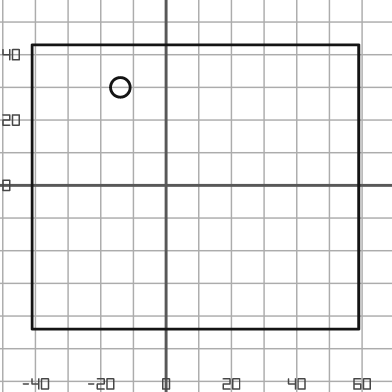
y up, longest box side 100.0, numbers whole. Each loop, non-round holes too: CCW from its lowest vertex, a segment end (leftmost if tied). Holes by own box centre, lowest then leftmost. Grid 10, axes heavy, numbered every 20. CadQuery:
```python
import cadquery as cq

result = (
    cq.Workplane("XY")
    .moveTo(-41.0, -44.0)
    .lineTo(59.0, -44.0)
    .lineTo(59.0, 43.0)
    .lineTo(-41.0, 43.0)
    .close()
    .moveTo(-14.0, 30.0)
    .circle(3.0)
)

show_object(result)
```